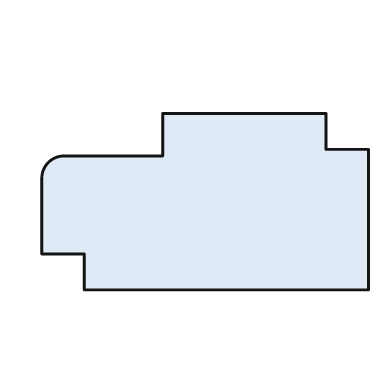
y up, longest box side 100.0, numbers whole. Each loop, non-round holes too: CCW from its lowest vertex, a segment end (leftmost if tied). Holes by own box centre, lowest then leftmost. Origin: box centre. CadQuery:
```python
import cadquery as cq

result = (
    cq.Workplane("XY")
    .moveTo(-37.0, -27.0)
    .lineTo(50.0, -27.0)
    .lineTo(50.0, 16.0)
    .lineTo(37.0, 16.0)
    .lineTo(37.0, 27.0)
    .lineTo(-13.0, 27.0)
    .lineTo(-13.0, 14.0)
    .lineTo(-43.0, 14.0)
    .threePointArc((-48.0, 12.0), (-50.0, 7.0))
    .lineTo(-50.0, -16.0)
    .lineTo(-37.0, -16.0)
    .close()
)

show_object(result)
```